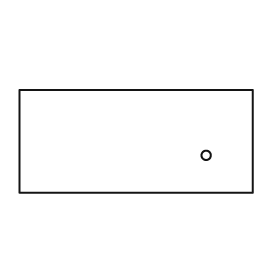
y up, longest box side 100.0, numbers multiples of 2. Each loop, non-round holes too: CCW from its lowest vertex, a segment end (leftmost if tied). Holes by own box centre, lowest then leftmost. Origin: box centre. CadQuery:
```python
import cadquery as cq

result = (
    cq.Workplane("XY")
    .moveTo(-50.0, -22.0)
    .lineTo(50.0, -22.0)
    .lineTo(50.0, 22.0)
    .lineTo(-50.0, 22.0)
    .close()
    .moveTo(30.0, -6.0)
    .circle(2.0)
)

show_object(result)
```